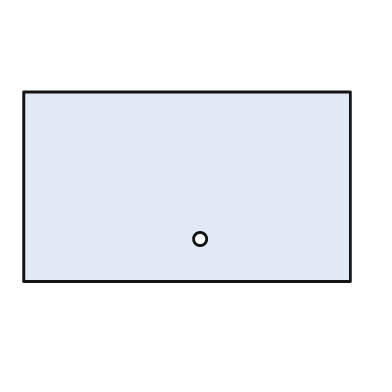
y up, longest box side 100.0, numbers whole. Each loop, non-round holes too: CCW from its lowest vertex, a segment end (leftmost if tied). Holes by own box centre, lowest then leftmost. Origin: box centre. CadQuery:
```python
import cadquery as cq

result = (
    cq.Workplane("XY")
    .moveTo(-50.0, -29.0)
    .lineTo(50.0, -29.0)
    .lineTo(50.0, 29.0)
    .lineTo(-50.0, 29.0)
    .close()
    .moveTo(4.0, -16.0)
    .circle(2.0)
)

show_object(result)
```